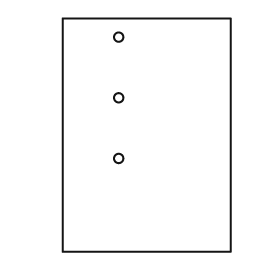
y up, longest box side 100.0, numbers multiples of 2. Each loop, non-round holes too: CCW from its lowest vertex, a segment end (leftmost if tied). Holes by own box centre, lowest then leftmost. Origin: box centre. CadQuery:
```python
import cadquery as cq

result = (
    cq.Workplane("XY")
    .moveTo(-36.0, -50.0)
    .lineTo(36.0, -50.0)
    .lineTo(36.0, 50.0)
    .lineTo(-36.0, 50.0)
    .close()
    .moveTo(-12.0, -10.0)
    .circle(2.0)
    .moveTo(-12.0, 16.0)
    .circle(2.0)
    .moveTo(-12.0, 42.0)
    .circle(2.0)
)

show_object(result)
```